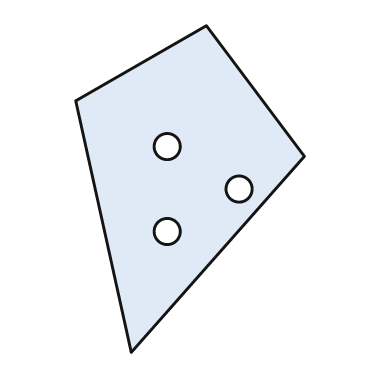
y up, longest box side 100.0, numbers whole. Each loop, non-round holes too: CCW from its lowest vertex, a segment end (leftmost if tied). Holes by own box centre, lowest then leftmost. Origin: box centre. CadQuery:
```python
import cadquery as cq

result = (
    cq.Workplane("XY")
    .moveTo(-18.0, -50.0)
    .lineTo(35.0, 10.0)
    .lineTo(5.0, 50.0)
    .lineTo(-35.0, 27.0)
    .close()
    .moveTo(-7.0, -13.0)
    .circle(4.0)
    .moveTo(15.0, 0.0)
    .circle(4.0)
    .moveTo(-7.0, 13.0)
    .circle(4.0)
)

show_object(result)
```